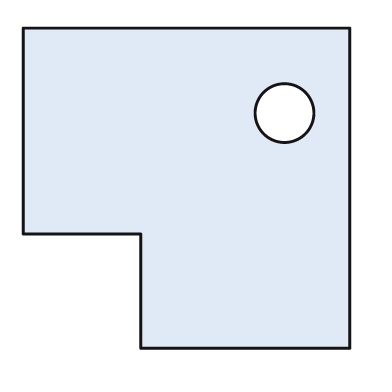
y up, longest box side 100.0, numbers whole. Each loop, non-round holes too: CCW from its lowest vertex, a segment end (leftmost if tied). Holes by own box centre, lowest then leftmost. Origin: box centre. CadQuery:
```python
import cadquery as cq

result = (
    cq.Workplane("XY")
    .moveTo(-14.0, -49.0)
    .lineTo(50.0, -49.0)
    .lineTo(50.0, 49.0)
    .lineTo(-50.0, 49.0)
    .lineTo(-50.0, -14.0)
    .lineTo(-14.0, -14.0)
    .close()
    .moveTo(30.0, 23.0)
    .circle(9.0)
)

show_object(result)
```